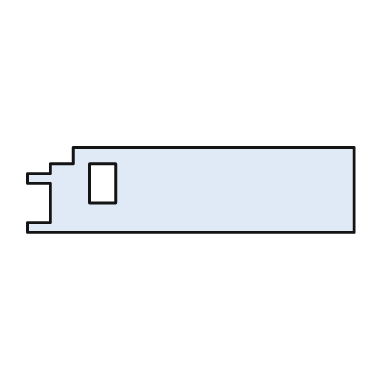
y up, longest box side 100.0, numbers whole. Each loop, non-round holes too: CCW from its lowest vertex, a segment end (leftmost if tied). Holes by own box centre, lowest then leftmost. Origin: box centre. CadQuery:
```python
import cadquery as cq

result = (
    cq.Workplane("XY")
    .moveTo(-50.0, -13.0)
    .lineTo(50.0, -13.0)
    .lineTo(50.0, 13.0)
    .lineTo(-36.0, 13.0)
    .lineTo(-36.0, 8.0)
    .lineTo(-43.0, 8.0)
    .lineTo(-43.0, 5.0)
    .lineTo(-50.0, 5.0)
    .lineTo(-50.0, 2.0)
    .lineTo(-43.0, 2.0)
    .lineTo(-43.0, -10.0)
    .lineTo(-50.0, -10.0)
    .close()
    .moveTo(-31.0, -4.0)
    .lineTo(-23.0, -4.0)
    .lineTo(-23.0, 8.0)
    .lineTo(-31.0, 8.0)
    .close()
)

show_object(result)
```